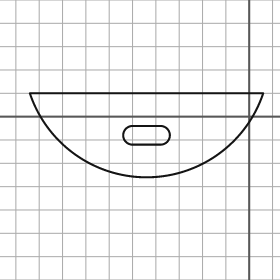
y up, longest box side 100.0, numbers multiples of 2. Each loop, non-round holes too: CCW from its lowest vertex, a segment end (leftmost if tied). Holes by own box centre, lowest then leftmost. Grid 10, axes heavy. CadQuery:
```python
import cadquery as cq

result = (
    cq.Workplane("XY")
    .moveTo(-94.0, 10.0)
    .threePointArc((-44.0, -26.0), (6.0, 10.0))
    .close()
    .moveTo(-50.0, -12.0)
    .lineTo(-38.0, -12.0)
    .threePointArc((-34.0, -8.0), (-38.0, -4.0))
    .lineTo(-50.0, -4.0)
    .threePointArc((-54.0, -8.0), (-50.0, -12.0))
    .close()
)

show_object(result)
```